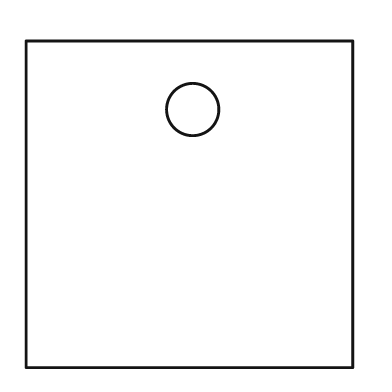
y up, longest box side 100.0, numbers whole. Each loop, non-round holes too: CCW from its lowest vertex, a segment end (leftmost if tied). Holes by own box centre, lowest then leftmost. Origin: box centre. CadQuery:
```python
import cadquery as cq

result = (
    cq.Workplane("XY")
    .moveTo(-50.0, -50.0)
    .lineTo(50.0, -50.0)
    .lineTo(50.0, 50.0)
    .lineTo(-50.0, 50.0)
    .close()
    .moveTo(1.0, 29.0)
    .circle(8.0)
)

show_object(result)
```